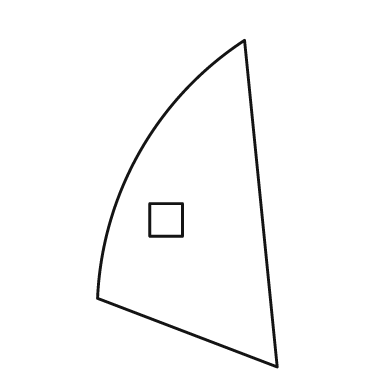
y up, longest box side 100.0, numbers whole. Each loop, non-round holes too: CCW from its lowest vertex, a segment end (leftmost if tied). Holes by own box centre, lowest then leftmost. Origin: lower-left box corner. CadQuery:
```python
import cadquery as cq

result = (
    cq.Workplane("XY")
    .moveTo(55.0, 0.0)
    .lineTo(45.0, 100.0)
    .threePointArc((13.0, 66.0), (0.0, 21.0))
    .close()
    .moveTo(16.0, 40.0)
    .lineTo(26.0, 40.0)
    .lineTo(26.0, 50.0)
    .lineTo(16.0, 50.0)
    .close()
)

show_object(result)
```